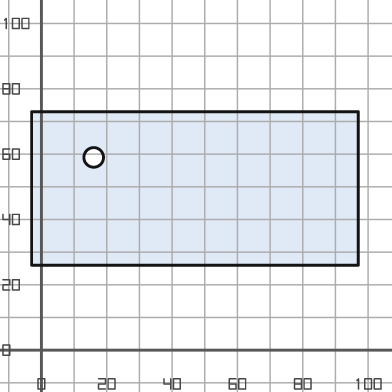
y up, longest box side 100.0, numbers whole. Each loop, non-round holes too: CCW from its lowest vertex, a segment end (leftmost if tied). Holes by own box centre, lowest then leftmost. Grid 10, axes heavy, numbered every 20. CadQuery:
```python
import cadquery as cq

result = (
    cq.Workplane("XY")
    .moveTo(-3.0, 26.0)
    .lineTo(97.0, 26.0)
    .lineTo(97.0, 73.0)
    .lineTo(-3.0, 73.0)
    .close()
    .moveTo(16.0, 59.0)
    .circle(3.0)
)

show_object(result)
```